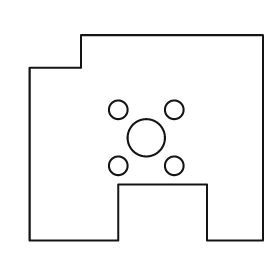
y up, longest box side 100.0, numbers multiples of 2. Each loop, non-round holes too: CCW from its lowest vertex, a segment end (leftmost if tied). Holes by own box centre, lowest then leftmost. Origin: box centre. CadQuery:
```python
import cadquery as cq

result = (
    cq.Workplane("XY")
    .moveTo(-50.0, -44.0)
    .lineTo(-12.0, -44.0)
    .lineTo(-12.0, -20.0)
    .lineTo(26.0, -20.0)
    .lineTo(26.0, -44.0)
    .lineTo(50.0, -44.0)
    .lineTo(50.0, 44.0)
    .lineTo(-28.0, 44.0)
    .lineTo(-28.0, 30.0)
    .lineTo(-50.0, 30.0)
    .close()
    .moveTo(-12.0, -12.0)
    .circle(4.0)
    .moveTo(12.0, -12.0)
    .circle(4.0)
    .moveTo(0.0, 0.0)
    .circle(8.0)
    .moveTo(-12.0, 12.0)
    .circle(4.0)
    .moveTo(12.0, 12.0)
    .circle(4.0)
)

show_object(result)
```